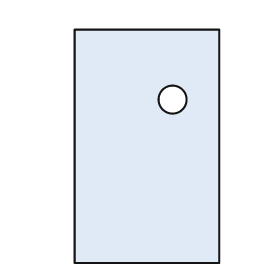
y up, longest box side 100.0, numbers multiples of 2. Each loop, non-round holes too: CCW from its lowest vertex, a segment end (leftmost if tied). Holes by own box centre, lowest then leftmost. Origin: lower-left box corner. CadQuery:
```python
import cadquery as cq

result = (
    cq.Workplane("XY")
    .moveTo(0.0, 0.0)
    .lineTo(62.0, 0.0)
    .lineTo(62.0, 100.0)
    .lineTo(0.0, 100.0)
    .close()
    .moveTo(42.0, 70.0)
    .circle(6.0)
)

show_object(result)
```